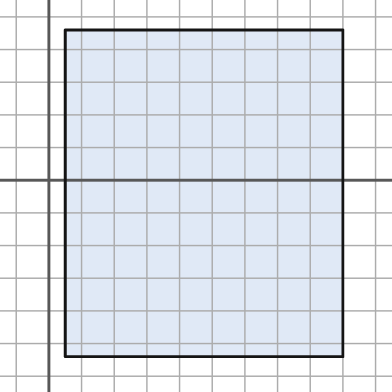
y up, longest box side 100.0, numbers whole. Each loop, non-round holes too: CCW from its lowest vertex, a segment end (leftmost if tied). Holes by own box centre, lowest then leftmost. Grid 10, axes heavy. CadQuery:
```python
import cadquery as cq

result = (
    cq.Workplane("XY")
    .moveTo(5.0, -54.0)
    .lineTo(90.0, -54.0)
    .lineTo(90.0, 46.0)
    .lineTo(5.0, 46.0)
    .close()
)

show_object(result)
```